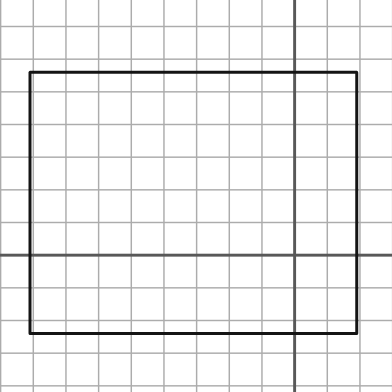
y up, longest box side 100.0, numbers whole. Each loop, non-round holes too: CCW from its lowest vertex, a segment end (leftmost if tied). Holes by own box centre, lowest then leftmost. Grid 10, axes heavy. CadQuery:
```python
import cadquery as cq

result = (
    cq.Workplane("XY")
    .moveTo(-81.0, -24.0)
    .lineTo(19.0, -24.0)
    .lineTo(19.0, 56.0)
    .lineTo(-81.0, 56.0)
    .close()
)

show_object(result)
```